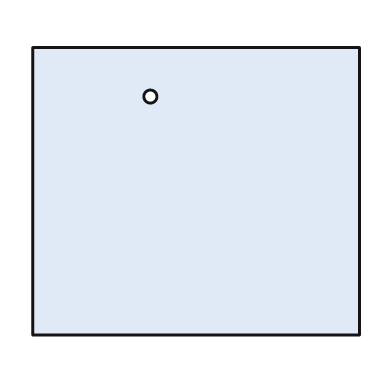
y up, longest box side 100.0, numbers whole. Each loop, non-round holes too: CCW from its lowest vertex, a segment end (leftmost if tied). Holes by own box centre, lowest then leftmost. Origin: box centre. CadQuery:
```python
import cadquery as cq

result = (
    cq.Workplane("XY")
    .moveTo(-50.0, -44.0)
    .lineTo(50.0, -44.0)
    .lineTo(50.0, 44.0)
    .lineTo(-50.0, 44.0)
    .close()
    .moveTo(-14.0, 29.0)
    .circle(2.0)
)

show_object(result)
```